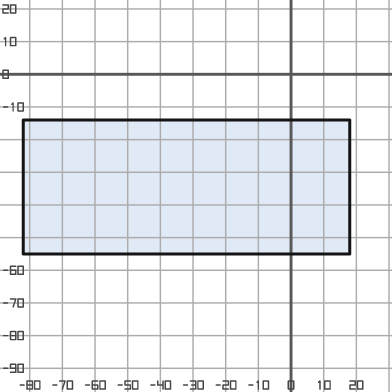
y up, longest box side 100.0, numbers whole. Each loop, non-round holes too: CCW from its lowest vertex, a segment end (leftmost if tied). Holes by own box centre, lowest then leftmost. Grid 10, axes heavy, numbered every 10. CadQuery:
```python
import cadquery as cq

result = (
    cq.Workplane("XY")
    .moveTo(-82.0, -55.0)
    .lineTo(18.0, -55.0)
    .lineTo(18.0, -14.0)
    .lineTo(-82.0, -14.0)
    .close()
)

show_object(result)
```